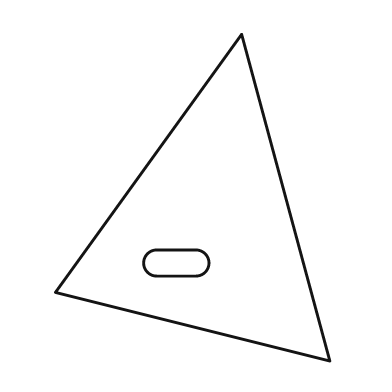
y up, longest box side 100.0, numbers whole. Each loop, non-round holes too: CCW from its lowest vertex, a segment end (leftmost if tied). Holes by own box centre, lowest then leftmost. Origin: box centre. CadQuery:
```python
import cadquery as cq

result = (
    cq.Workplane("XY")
    .moveTo(42.0, -50.0)
    .lineTo(15.0, 50.0)
    .lineTo(-42.0, -29.0)
    .close()
    .moveTo(-11.0, -24.0)
    .lineTo(1.0, -24.0)
    .threePointArc((5.0, -20.0), (1.0, -16.0))
    .lineTo(-11.0, -16.0)
    .threePointArc((-15.0, -20.0), (-11.0, -24.0))
    .close()
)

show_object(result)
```